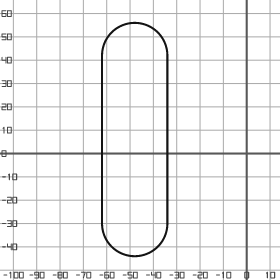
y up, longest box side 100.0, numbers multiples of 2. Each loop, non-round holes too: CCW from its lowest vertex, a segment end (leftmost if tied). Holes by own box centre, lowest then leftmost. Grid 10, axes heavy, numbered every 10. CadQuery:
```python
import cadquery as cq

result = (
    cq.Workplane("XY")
    .moveTo(-62.0, -30.0)
    .threePointArc((-48.0, -44.0), (-34.0, -30.0))
    .lineTo(-34.0, 42.0)
    .threePointArc((-48.0, 56.0), (-62.0, 42.0))
    .close()
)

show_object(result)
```